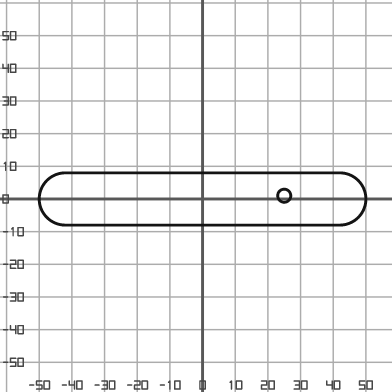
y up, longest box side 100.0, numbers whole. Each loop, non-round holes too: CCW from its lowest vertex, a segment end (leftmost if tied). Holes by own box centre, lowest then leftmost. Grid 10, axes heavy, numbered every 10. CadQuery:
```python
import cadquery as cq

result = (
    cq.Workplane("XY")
    .moveTo(-42.0, -8.0)
    .lineTo(42.0, -8.0)
    .threePointArc((50.0, 0.0), (42.0, 8.0))
    .lineTo(-42.0, 8.0)
    .threePointArc((-50.0, 0.0), (-42.0, -8.0))
    .close()
    .moveTo(25.0, 1.0)
    .circle(2.0)
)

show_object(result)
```